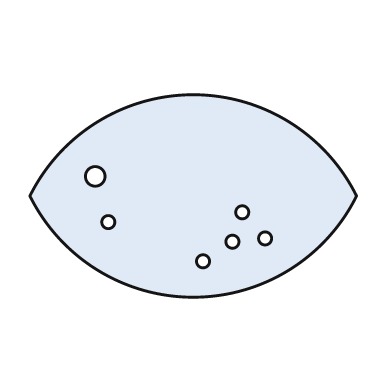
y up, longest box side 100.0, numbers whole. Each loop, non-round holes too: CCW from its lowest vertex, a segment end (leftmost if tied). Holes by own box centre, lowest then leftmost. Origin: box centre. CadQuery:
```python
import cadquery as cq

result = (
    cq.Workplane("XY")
    .moveTo(-50.0, 0.0)
    .threePointArc((0.0, -31.0), (50.0, 0.0))
    .threePointArc((0.0, 31.0), (-50.0, 0.0))
    .close()
    .moveTo(3.0, -20.0)
    .circle(2.0)
    .moveTo(12.0, -14.0)
    .circle(2.0)
    .moveTo(22.0, -13.0)
    .circle(2.0)
    .moveTo(-26.0, -8.0)
    .circle(2.0)
    .moveTo(15.0, -5.0)
    .circle(2.0)
    .moveTo(-30.0, 6.0)
    .circle(3.0)
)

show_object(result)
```